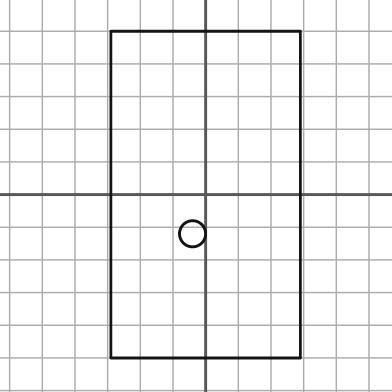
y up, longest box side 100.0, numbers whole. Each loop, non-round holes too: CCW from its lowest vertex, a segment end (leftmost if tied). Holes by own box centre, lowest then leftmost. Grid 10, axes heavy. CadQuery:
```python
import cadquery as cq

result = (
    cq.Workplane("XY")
    .moveTo(-29.0, -50.0)
    .lineTo(29.0, -50.0)
    .lineTo(29.0, 50.0)
    .lineTo(-29.0, 50.0)
    .close()
    .moveTo(-4.0, -12.0)
    .circle(4.0)
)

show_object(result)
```